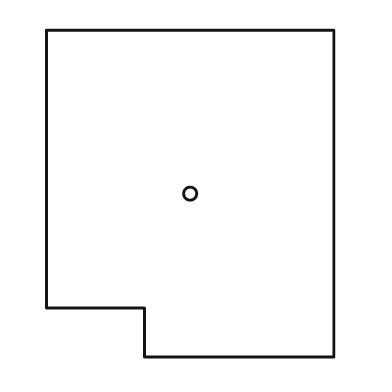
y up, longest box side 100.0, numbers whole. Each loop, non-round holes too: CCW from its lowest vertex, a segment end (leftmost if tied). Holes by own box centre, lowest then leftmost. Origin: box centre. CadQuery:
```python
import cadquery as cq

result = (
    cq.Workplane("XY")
    .moveTo(-14.0, -50.0)
    .lineTo(44.0, -50.0)
    .lineTo(44.0, 50.0)
    .lineTo(-44.0, 50.0)
    .lineTo(-44.0, -35.0)
    .lineTo(-14.0, -35.0)
    .close()
    .moveTo(0.0, 0.0)
    .circle(2.0)
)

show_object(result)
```